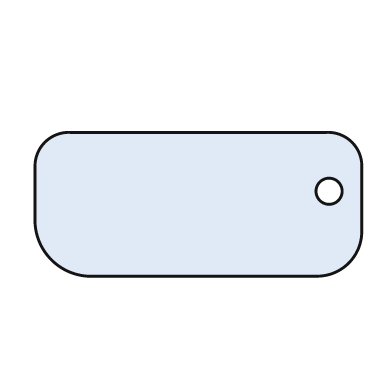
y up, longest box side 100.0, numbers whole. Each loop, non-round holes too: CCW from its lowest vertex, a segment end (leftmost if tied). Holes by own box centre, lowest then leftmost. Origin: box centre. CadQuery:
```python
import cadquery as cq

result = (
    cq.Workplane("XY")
    .moveTo(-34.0, -22.0)
    .lineTo(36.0, -22.0)
    .threePointArc((46.0, -18.0), (50.0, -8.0))
    .lineTo(50.0, 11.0)
    .threePointArc((47.0, 19.0), (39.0, 22.0))
    .lineTo(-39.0, 22.0)
    .threePointArc((-47.0, 19.0), (-50.0, 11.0))
    .lineTo(-50.0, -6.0)
    .threePointArc((-45.0, -17.0), (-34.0, -22.0))
    .close()
    .moveTo(40.0, 4.0)
    .circle(4.0)
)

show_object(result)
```